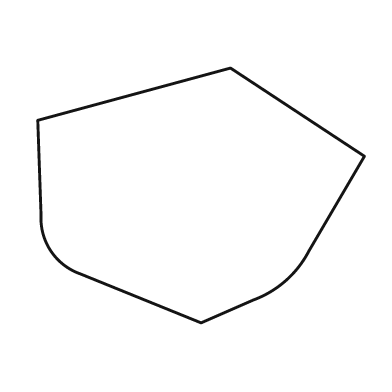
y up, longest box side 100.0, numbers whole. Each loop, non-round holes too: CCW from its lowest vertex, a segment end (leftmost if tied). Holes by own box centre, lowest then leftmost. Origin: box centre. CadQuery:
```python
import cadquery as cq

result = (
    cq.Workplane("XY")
    .moveTo(0.0, -39.0)
    .lineTo(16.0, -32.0)
    .threePointArc((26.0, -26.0), (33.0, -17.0))
    .lineTo(50.0, 12.0)
    .lineTo(9.0, 39.0)
    .lineTo(-50.0, 23.0)
    .lineTo(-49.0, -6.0)
    .threePointArc((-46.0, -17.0), (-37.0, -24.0))
    .close()
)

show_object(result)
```